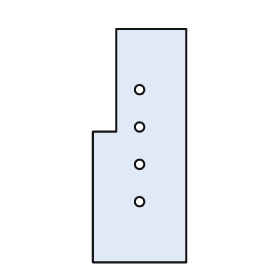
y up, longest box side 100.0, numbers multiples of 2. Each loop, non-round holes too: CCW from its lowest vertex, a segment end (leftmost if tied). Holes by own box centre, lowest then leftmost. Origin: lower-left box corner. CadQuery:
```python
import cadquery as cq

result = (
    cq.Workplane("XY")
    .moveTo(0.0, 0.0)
    .lineTo(40.0, 0.0)
    .lineTo(40.0, 100.0)
    .lineTo(10.0, 100.0)
    .lineTo(10.0, 56.0)
    .lineTo(0.0, 56.0)
    .close()
    .moveTo(20.0, 26.0)
    .circle(2.0)
    .moveTo(20.0, 42.0)
    .circle(2.0)
    .moveTo(20.0, 58.0)
    .circle(2.0)
    .moveTo(20.0, 74.0)
    .circle(2.0)
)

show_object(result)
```